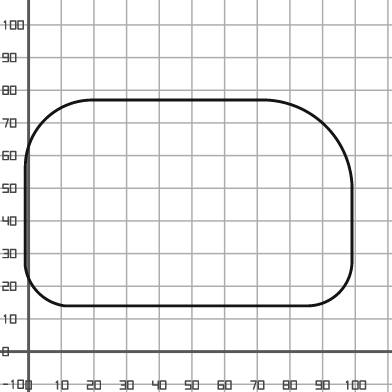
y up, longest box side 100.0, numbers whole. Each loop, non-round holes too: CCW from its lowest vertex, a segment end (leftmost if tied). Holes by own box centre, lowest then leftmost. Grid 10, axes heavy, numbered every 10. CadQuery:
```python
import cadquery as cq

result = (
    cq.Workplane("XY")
    .moveTo(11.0, 14.0)
    .lineTo(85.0, 14.0)
    .threePointArc((95.0, 18.0), (99.0, 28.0))
    .lineTo(99.0, 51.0)
    .threePointArc((91.0, 69.0), (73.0, 77.0))
    .lineTo(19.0, 77.0)
    .threePointArc((5.0, 71.0), (-1.0, 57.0))
    .lineTo(-1.0, 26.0)
    .threePointArc((3.0, 18.0), (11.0, 14.0))
    .close()
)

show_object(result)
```